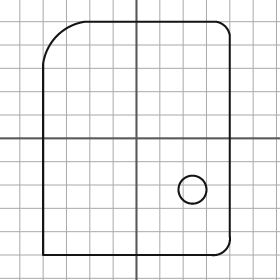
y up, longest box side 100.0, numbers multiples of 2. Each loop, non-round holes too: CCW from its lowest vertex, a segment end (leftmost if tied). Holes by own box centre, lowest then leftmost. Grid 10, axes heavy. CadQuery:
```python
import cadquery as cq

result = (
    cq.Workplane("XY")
    .moveTo(-40.0, -50.0)
    .lineTo(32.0, -50.0)
    .threePointArc((38.0, -48.0), (40.0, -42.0))
    .lineTo(40.0, 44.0)
    .threePointArc((38.0, 48.0), (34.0, 50.0))
    .lineTo(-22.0, 50.0)
    .threePointArc((-34.0, 44.0), (-40.0, 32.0))
    .close()
    .moveTo(24.0, -22.0)
    .circle(6.0)
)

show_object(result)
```